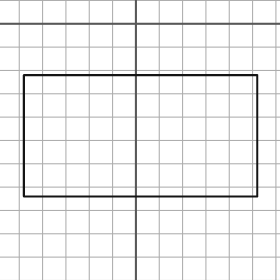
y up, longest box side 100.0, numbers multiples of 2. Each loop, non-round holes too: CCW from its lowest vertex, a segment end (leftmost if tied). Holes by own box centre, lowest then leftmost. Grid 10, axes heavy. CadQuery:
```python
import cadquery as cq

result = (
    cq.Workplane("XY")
    .moveTo(-48.0, -74.0)
    .lineTo(52.0, -74.0)
    .lineTo(52.0, -22.0)
    .lineTo(-48.0, -22.0)
    .close()
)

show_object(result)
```